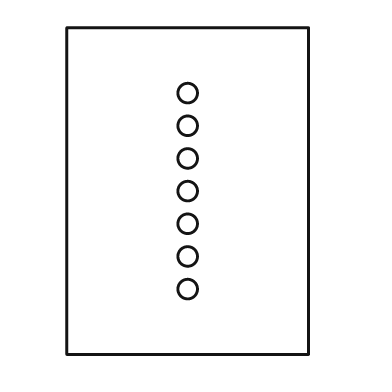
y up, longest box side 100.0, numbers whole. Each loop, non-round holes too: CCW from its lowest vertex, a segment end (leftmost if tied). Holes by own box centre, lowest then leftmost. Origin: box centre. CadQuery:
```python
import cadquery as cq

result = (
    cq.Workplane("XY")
    .moveTo(-37.0, -50.0)
    .lineTo(37.0, -50.0)
    .lineTo(37.0, 50.0)
    .lineTo(-37.0, 50.0)
    .close()
    .moveTo(0.0, -30.0)
    .circle(3.0)
    .moveTo(0.0, -20.0)
    .circle(3.0)
    .moveTo(0.0, -10.0)
    .circle(3.0)
    .moveTo(0.0, 0.0)
    .circle(3.0)
    .moveTo(0.0, 10.0)
    .circle(3.0)
    .moveTo(0.0, 20.0)
    .circle(3.0)
    .moveTo(0.0, 30.0)
    .circle(3.0)
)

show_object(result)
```